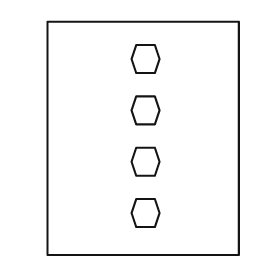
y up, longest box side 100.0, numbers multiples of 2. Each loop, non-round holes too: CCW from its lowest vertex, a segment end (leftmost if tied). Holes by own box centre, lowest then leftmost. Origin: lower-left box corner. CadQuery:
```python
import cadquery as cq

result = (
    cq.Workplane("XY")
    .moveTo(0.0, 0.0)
    .lineTo(82.0, 0.0)
    .lineTo(82.0, 100.0)
    .lineTo(0.0, 100.0)
    .close()
    .moveTo(38.0, 12.0)
    .lineTo(46.0, 12.0)
    .lineTo(48.0, 18.0)
    .lineTo(46.0, 24.0)
    .lineTo(38.0, 24.0)
    .lineTo(36.0, 18.0)
    .close()
    .moveTo(38.0, 34.0)
    .lineTo(46.0, 34.0)
    .lineTo(48.0, 40.0)
    .lineTo(46.0, 46.0)
    .lineTo(38.0, 46.0)
    .lineTo(36.0, 40.0)
    .close()
    .moveTo(38.0, 56.0)
    .lineTo(46.0, 56.0)
    .lineTo(48.0, 62.0)
    .lineTo(46.0, 68.0)
    .lineTo(38.0, 68.0)
    .lineTo(36.0, 62.0)
    .close()
    .moveTo(38.0, 78.0)
    .lineTo(46.0, 78.0)
    .lineTo(48.0, 84.0)
    .lineTo(46.0, 90.0)
    .lineTo(38.0, 90.0)
    .lineTo(36.0, 84.0)
    .close()
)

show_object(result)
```